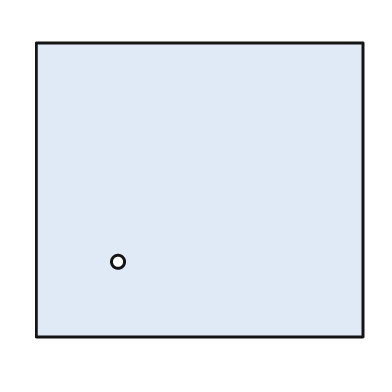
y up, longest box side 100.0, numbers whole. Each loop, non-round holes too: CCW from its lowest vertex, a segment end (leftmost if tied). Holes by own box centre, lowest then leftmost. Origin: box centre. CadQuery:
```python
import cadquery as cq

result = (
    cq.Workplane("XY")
    .moveTo(-50.0, -45.0)
    .lineTo(50.0, -45.0)
    .lineTo(50.0, 45.0)
    .lineTo(-50.0, 45.0)
    .close()
    .moveTo(-25.0, -22.0)
    .circle(2.0)
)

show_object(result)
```